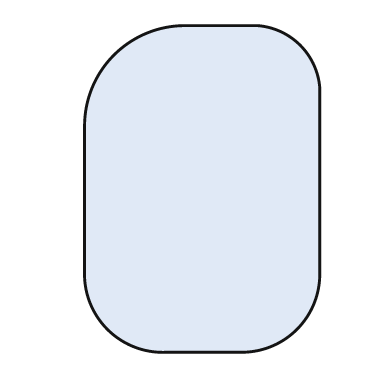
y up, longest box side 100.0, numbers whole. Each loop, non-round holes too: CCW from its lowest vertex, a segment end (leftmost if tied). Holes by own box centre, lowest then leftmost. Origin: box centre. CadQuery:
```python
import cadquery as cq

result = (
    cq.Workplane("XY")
    .moveTo(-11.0, -50.0)
    .lineTo(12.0, -50.0)
    .threePointArc((29.0, -43.0), (36.0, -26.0))
    .lineTo(36.0, 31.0)
    .threePointArc((30.0, 44.0), (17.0, 50.0))
    .lineTo(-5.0, 50.0)
    .threePointArc((-27.0, 41.0), (-36.0, 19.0))
    .lineTo(-36.0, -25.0)
    .threePointArc((-29.0, -43.0), (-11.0, -50.0))
    .close()
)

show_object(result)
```